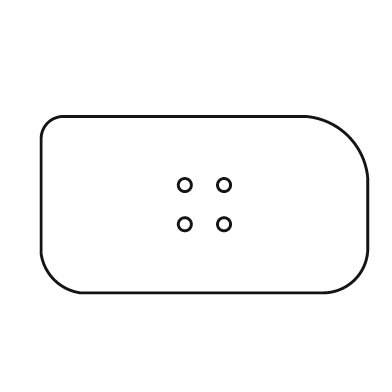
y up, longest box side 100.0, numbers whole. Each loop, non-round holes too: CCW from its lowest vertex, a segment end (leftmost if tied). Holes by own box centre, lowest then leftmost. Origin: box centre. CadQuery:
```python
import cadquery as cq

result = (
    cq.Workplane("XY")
    .moveTo(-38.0, -27.0)
    .lineTo(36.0, -27.0)
    .threePointArc((46.0, -23.0), (50.0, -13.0))
    .lineTo(50.0, 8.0)
    .threePointArc((44.0, 21.0), (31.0, 27.0))
    .lineTo(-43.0, 27.0)
    .threePointArc((-48.0, 25.0), (-50.0, 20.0))
    .lineTo(-50.0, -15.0)
    .threePointArc((-46.0, -23.0), (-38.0, -27.0))
    .close()
    .moveTo(-6.0, -6.0)
    .circle(2.0)
    .moveTo(6.0, -6.0)
    .circle(2.0)
    .moveTo(-6.0, 6.0)
    .circle(2.0)
    .moveTo(6.0, 6.0)
    .circle(2.0)
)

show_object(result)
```